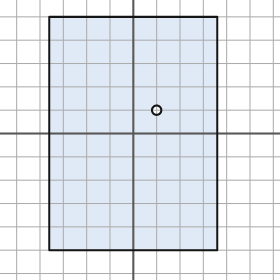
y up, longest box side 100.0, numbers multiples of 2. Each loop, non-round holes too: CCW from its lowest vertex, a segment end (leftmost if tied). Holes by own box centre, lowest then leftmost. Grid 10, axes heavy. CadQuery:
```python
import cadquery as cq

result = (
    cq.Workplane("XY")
    .moveTo(-36.0, -50.0)
    .lineTo(36.0, -50.0)
    .lineTo(36.0, 50.0)
    .lineTo(-36.0, 50.0)
    .close()
    .moveTo(10.0, 10.0)
    .circle(2.0)
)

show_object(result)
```